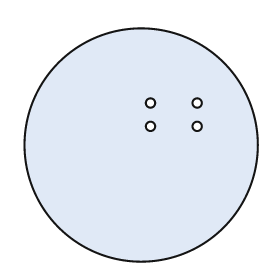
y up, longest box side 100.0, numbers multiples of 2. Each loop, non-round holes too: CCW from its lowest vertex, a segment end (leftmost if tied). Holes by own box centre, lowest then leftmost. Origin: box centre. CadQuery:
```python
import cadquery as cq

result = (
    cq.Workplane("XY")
    .moveTo(0.0, 0.0)
    .circle(50.0)
    .moveTo(4.0, 8.0)
    .circle(2.0)
    .moveTo(24.0, 8.0)
    .circle(2.0)
    .moveTo(4.0, 18.0)
    .circle(2.0)
    .moveTo(24.0, 18.0)
    .circle(2.0)
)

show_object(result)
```